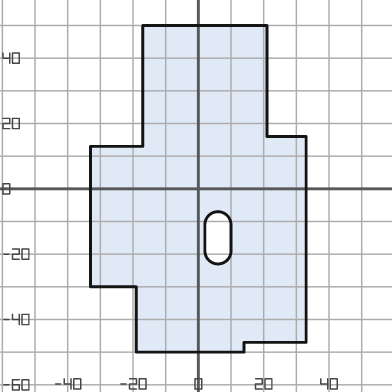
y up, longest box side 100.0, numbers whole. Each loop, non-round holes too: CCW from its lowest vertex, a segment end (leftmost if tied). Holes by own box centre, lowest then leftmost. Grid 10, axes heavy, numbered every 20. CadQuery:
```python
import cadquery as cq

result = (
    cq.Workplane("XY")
    .moveTo(-19.0, -50.0)
    .lineTo(14.0, -50.0)
    .lineTo(14.0, -47.0)
    .lineTo(33.0, -47.0)
    .lineTo(33.0, 16.0)
    .lineTo(21.0, 16.0)
    .lineTo(21.0, 50.0)
    .lineTo(-17.0, 50.0)
    .lineTo(-17.0, 13.0)
    .lineTo(-33.0, 13.0)
    .lineTo(-33.0, -30.0)
    .lineTo(-19.0, -30.0)
    .close()
    .moveTo(2.0, -19.0)
    .threePointArc((6.0, -23.0), (10.0, -19.0))
    .lineTo(10.0, -11.0)
    .threePointArc((6.0, -7.0), (2.0, -11.0))
    .close()
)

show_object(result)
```